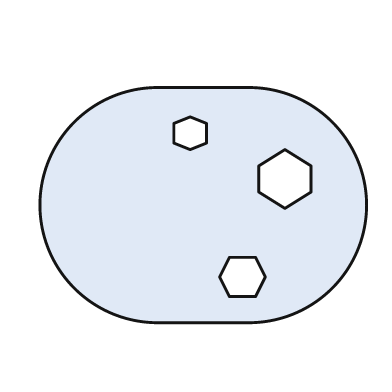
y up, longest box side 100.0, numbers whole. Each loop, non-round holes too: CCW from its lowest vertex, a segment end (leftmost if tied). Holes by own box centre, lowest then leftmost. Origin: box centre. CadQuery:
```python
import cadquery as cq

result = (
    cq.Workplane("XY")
    .moveTo(-14.0, -36.0)
    .lineTo(14.0, -36.0)
    .threePointArc((50.0, 0.0), (14.0, 36.0))
    .lineTo(-14.0, 36.0)
    .threePointArc((-50.0, 0.0), (-14.0, -36.0))
    .close()
    .moveTo(8.0, -28.0)
    .lineTo(16.0, -28.0)
    .lineTo(19.0, -22.0)
    .lineTo(16.0, -16.0)
    .lineTo(8.0, -16.0)
    .lineTo(5.0, -22.0)
    .close()
    .moveTo(25.0, -1.0)
    .lineTo(33.0, 4.0)
    .lineTo(33.0, 12.0)
    .lineTo(25.0, 17.0)
    .lineTo(17.0, 12.0)
    .lineTo(17.0, 4.0)
    .close()
    .moveTo(-4.0, 17.0)
    .lineTo(1.0, 19.0)
    .lineTo(1.0, 25.0)
    .lineTo(-4.0, 27.0)
    .lineTo(-9.0, 25.0)
    .lineTo(-9.0, 19.0)
    .close()
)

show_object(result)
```